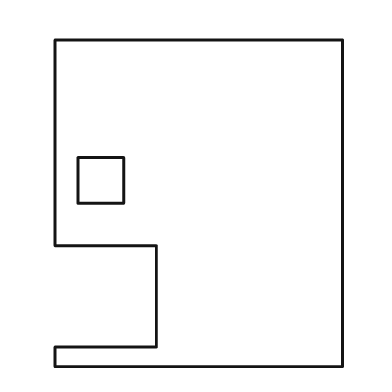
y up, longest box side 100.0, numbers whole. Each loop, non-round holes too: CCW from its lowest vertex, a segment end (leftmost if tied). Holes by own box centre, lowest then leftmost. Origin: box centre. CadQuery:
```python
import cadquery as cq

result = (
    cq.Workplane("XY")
    .moveTo(-44.0, -50.0)
    .lineTo(44.0, -50.0)
    .lineTo(44.0, 50.0)
    .lineTo(-44.0, 50.0)
    .lineTo(-44.0, -13.0)
    .lineTo(-13.0, -13.0)
    .lineTo(-13.0, -44.0)
    .lineTo(-44.0, -44.0)
    .close()
    .moveTo(-37.0, 0.0)
    .lineTo(-23.0, 0.0)
    .lineTo(-23.0, 14.0)
    .lineTo(-37.0, 14.0)
    .close()
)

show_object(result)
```